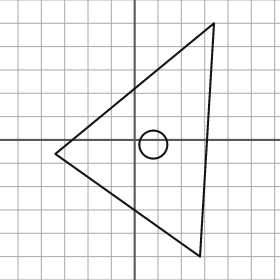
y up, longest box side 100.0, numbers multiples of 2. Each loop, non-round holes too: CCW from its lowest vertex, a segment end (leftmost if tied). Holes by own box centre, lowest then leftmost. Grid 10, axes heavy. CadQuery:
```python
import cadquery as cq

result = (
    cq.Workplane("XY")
    .moveTo(28.0, -50.0)
    .lineTo(34.0, 50.0)
    .lineTo(-34.0, -6.0)
    .close()
    .moveTo(8.0, -2.0)
    .circle(6.0)
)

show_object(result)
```